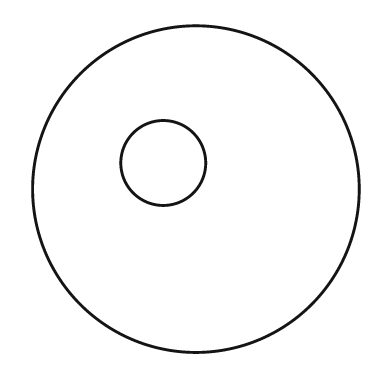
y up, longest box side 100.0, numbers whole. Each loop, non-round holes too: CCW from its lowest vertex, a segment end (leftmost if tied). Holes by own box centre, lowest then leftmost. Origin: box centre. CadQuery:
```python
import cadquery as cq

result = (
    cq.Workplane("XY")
    .moveTo(0.0, 0.0)
    .circle(50.0)
    .moveTo(-10.0, 8.0)
    .circle(13.0)
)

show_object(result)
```